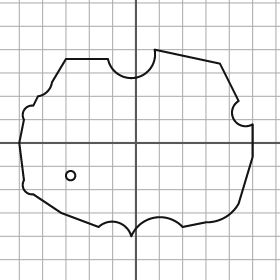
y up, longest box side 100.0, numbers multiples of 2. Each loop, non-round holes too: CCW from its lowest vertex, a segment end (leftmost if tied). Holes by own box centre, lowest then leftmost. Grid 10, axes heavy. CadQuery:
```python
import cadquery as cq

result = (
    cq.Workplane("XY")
    .moveTo(-2.0, -40.0)
    .threePointArc((8.0, -32.0), (20.0, -36.0))
    .lineTo(30.0, -34.0)
    .threePointArc((38.0, -32.0), (44.0, -26.0))
    .lineTo(50.0, -6.0)
    .lineTo(50.0, 8.0)
    .threePointArc((42.0, 10.0), (44.0, 18.0))
    .lineTo(36.0, 34.0)
    .lineTo(8.0, 40.0)
    .threePointArc((0.0, 28.0), (-12.0, 36.0))
    .lineTo(-30.0, 36.0)
    .lineTo(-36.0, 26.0)
    .threePointArc((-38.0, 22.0), (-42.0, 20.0))
    .lineTo(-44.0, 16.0)
    .threePointArc((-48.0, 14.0), (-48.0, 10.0))
    .lineTo(-50.0, 0.0)
    .lineTo(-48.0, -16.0)
    .threePointArc((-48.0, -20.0), (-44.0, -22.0))
    .lineTo(-32.0, -30.0)
    .lineTo(-16.0, -36.0)
    .threePointArc((-8.0, -34.0), (-2.0, -40.0))
    .close()
    .moveTo(-28.0, -14.0)
    .circle(2.0)
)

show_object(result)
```